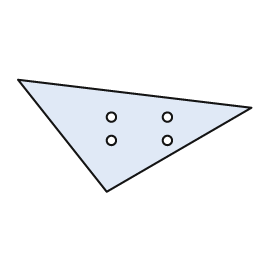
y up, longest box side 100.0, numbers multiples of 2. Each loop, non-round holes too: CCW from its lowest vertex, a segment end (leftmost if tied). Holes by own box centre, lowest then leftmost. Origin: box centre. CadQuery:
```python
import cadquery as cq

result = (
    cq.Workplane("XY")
    .moveTo(-12.0, -24.0)
    .lineTo(50.0, 12.0)
    .lineTo(-50.0, 24.0)
    .close()
    .moveTo(-10.0, -2.0)
    .circle(2.0)
    .moveTo(14.0, -2.0)
    .circle(2.0)
    .moveTo(-10.0, 8.0)
    .circle(2.0)
    .moveTo(14.0, 8.0)
    .circle(2.0)
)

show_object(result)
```